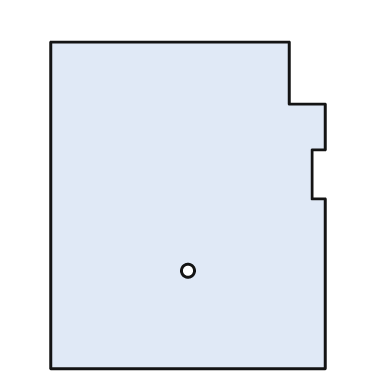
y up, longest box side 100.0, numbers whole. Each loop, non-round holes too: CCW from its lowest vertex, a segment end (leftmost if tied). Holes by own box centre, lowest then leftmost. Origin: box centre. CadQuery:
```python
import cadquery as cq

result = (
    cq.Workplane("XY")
    .moveTo(-42.0, -50.0)
    .lineTo(42.0, -50.0)
    .lineTo(42.0, 2.0)
    .lineTo(38.0, 2.0)
    .lineTo(38.0, 17.0)
    .lineTo(42.0, 17.0)
    .lineTo(42.0, 31.0)
    .lineTo(31.0, 31.0)
    .lineTo(31.0, 50.0)
    .lineTo(-42.0, 50.0)
    .close()
    .moveTo(0.0, -20.0)
    .circle(2.0)
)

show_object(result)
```